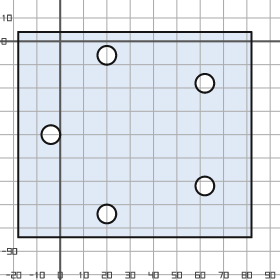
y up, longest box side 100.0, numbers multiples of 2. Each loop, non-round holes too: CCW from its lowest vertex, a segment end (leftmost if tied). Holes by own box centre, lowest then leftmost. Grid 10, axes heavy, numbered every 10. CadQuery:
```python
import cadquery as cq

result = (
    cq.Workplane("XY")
    .moveTo(-18.0, -84.0)
    .lineTo(82.0, -84.0)
    .lineTo(82.0, 4.0)
    .lineTo(-18.0, 4.0)
    .close()
    .moveTo(20.0, -74.0)
    .circle(4.0)
    .moveTo(62.0, -62.0)
    .circle(4.0)
    .moveTo(-4.0, -40.0)
    .circle(4.0)
    .moveTo(62.0, -18.0)
    .circle(4.0)
    .moveTo(20.0, -6.0)
    .circle(4.0)
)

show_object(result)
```